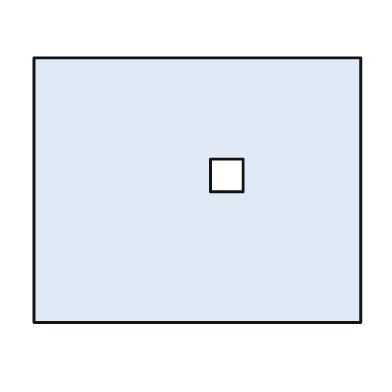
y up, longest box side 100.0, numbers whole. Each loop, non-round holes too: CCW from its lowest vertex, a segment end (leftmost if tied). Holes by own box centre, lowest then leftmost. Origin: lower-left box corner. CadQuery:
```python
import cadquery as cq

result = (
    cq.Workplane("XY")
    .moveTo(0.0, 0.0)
    .lineTo(100.0, 0.0)
    .lineTo(100.0, 81.0)
    .lineTo(0.0, 81.0)
    .close()
    .moveTo(54.0, 40.0)
    .lineTo(64.0, 40.0)
    .lineTo(64.0, 50.0)
    .lineTo(54.0, 50.0)
    .close()
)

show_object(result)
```